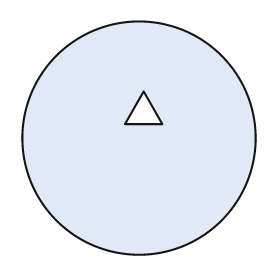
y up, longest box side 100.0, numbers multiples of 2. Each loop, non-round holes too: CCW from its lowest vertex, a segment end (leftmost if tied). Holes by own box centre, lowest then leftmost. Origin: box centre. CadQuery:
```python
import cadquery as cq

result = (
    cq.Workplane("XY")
    .moveTo(0.0, 0.0)
    .circle(50.0)
    .moveTo(-6.0, 6.0)
    .lineTo(10.0, 6.0)
    .lineTo(2.0, 20.0)
    .close()
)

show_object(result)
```